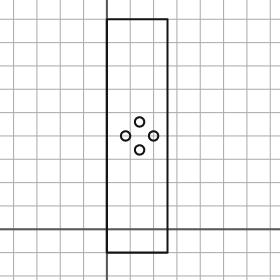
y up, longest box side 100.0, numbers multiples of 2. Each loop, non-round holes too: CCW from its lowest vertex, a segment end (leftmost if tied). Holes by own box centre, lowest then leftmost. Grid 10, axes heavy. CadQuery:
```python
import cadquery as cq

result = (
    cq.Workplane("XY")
    .moveTo(0.0, -10.0)
    .lineTo(26.0, -10.0)
    .lineTo(26.0, 90.0)
    .lineTo(0.0, 90.0)
    .close()
    .moveTo(14.0, 34.0)
    .circle(2.0)
    .moveTo(8.0, 40.0)
    .circle(2.0)
    .moveTo(20.0, 40.0)
    .circle(2.0)
    .moveTo(14.0, 46.0)
    .circle(2.0)
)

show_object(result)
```